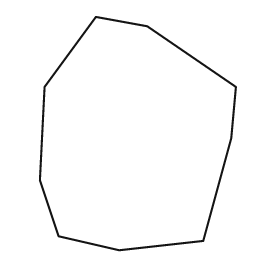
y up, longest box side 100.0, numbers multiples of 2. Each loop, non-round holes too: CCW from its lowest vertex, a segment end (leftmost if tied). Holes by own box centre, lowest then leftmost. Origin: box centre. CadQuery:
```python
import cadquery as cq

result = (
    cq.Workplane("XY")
    .moveTo(-8.0, -50.0)
    .lineTo(28.0, -46.0)
    .lineTo(40.0, -2.0)
    .lineTo(42.0, 20.0)
    .lineTo(4.0, 46.0)
    .lineTo(-18.0, 50.0)
    .lineTo(-40.0, 20.0)
    .lineTo(-42.0, -20.0)
    .lineTo(-34.0, -44.0)
    .close()
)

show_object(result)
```